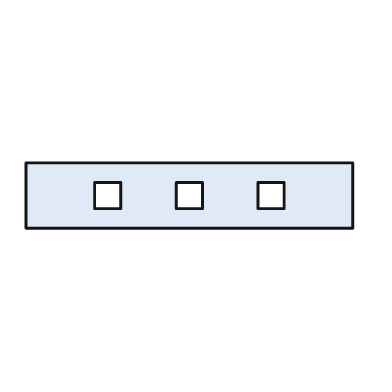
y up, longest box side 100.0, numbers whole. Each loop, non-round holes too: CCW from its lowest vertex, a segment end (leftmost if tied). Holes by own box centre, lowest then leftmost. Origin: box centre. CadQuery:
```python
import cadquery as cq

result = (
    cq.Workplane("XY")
    .moveTo(-50.0, -10.0)
    .lineTo(50.0, -10.0)
    .lineTo(50.0, 10.0)
    .lineTo(-50.0, 10.0)
    .close()
    .moveTo(-29.0, -4.0)
    .lineTo(-21.0, -4.0)
    .lineTo(-21.0, 4.0)
    .lineTo(-29.0, 4.0)
    .close()
    .moveTo(-4.0, -4.0)
    .lineTo(4.0, -4.0)
    .lineTo(4.0, 4.0)
    .lineTo(-4.0, 4.0)
    .close()
    .moveTo(21.0, -4.0)
    .lineTo(29.0, -4.0)
    .lineTo(29.0, 4.0)
    .lineTo(21.0, 4.0)
    .close()
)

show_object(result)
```